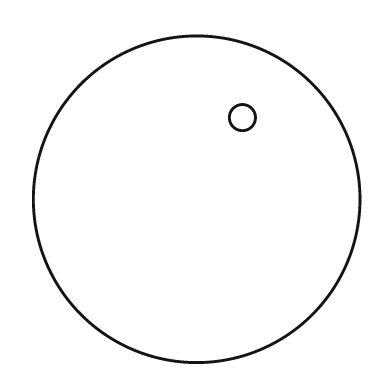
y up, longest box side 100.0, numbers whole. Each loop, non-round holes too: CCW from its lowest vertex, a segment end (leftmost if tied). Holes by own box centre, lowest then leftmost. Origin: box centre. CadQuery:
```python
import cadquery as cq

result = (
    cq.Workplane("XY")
    .moveTo(0.0, 0.0)
    .circle(50.0)
    .moveTo(14.0, 25.0)
    .circle(4.0)
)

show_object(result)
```